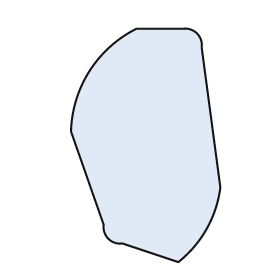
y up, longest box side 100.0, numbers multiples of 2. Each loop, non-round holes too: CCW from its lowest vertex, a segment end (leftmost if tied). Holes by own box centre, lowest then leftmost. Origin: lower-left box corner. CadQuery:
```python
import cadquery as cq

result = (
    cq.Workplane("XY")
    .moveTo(46.0, 0.0)
    .threePointArc((58.0, 14.0), (64.0, 32.0))
    .lineTo(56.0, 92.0)
    .threePointArc((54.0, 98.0), (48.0, 100.0))
    .lineTo(28.0, 100.0)
    .threePointArc((8.0, 82.0), (0.0, 56.0))
    .lineTo(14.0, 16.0)
    .threePointArc((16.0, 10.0), (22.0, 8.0))
    .close()
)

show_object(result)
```